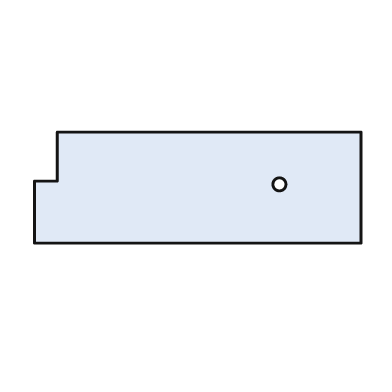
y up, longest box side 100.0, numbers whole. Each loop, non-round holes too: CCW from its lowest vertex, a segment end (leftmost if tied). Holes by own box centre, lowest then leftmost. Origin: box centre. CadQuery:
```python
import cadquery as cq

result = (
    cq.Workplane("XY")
    .moveTo(-50.0, -17.0)
    .lineTo(50.0, -17.0)
    .lineTo(50.0, 17.0)
    .lineTo(-43.0, 17.0)
    .lineTo(-43.0, 2.0)
    .lineTo(-50.0, 2.0)
    .close()
    .moveTo(25.0, 1.0)
    .circle(2.0)
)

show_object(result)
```